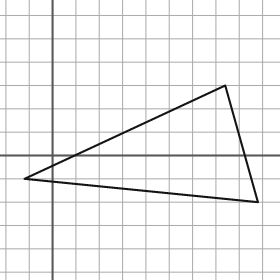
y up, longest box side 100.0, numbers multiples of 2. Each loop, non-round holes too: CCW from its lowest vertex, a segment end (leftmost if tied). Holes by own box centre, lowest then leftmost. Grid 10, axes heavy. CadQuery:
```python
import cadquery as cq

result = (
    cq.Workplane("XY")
    .moveTo(88.0, -20.0)
    .lineTo(74.0, 30.0)
    .lineTo(-12.0, -10.0)
    .close()
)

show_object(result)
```